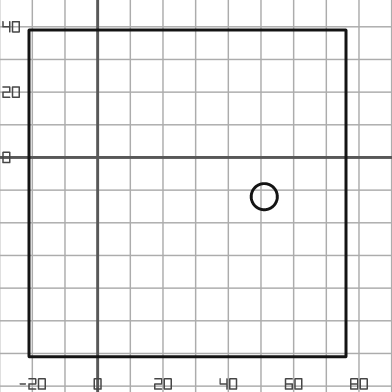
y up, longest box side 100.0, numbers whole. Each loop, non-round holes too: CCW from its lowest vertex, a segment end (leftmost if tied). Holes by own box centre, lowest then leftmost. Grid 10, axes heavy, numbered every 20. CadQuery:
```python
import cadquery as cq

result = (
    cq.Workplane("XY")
    .moveTo(-21.0, -61.0)
    .lineTo(76.0, -61.0)
    .lineTo(76.0, 39.0)
    .lineTo(-21.0, 39.0)
    .close()
    .moveTo(51.0, -12.0)
    .circle(4.0)
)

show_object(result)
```